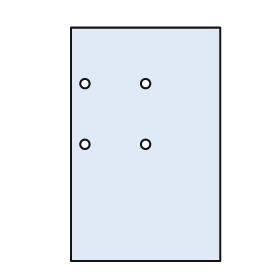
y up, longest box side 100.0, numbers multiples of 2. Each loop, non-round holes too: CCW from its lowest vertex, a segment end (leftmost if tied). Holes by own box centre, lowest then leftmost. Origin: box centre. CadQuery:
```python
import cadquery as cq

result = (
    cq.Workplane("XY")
    .moveTo(-32.0, -50.0)
    .lineTo(32.0, -50.0)
    .lineTo(32.0, 50.0)
    .lineTo(-32.0, 50.0)
    .close()
    .moveTo(-26.0, 0.0)
    .circle(2.0)
    .moveTo(0.0, 0.0)
    .circle(2.0)
    .moveTo(-26.0, 26.0)
    .circle(2.0)
    .moveTo(0.0, 26.0)
    .circle(2.0)
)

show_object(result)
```